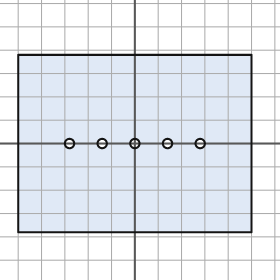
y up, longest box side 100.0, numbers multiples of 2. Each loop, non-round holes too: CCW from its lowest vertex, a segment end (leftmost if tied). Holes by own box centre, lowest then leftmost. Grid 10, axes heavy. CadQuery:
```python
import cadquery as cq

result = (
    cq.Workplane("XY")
    .moveTo(-50.0, -38.0)
    .lineTo(50.0, -38.0)
    .lineTo(50.0, 38.0)
    .lineTo(-50.0, 38.0)
    .close()
    .moveTo(-28.0, 0.0)
    .circle(2.0)
    .moveTo(-14.0, 0.0)
    .circle(2.0)
    .moveTo(0.0, 0.0)
    .circle(2.0)
    .moveTo(14.0, 0.0)
    .circle(2.0)
    .moveTo(28.0, 0.0)
    .circle(2.0)
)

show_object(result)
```